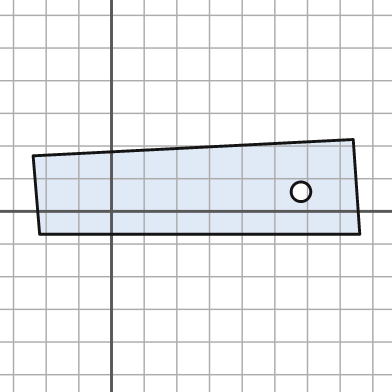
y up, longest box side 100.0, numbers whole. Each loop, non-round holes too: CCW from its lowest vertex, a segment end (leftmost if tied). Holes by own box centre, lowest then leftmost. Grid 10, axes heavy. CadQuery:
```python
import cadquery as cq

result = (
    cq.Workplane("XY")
    .moveTo(-22.0, -7.0)
    .lineTo(76.0, -7.0)
    .lineTo(74.0, 22.0)
    .lineTo(-24.0, 17.0)
    .close()
    .moveTo(58.0, 6.0)
    .circle(3.0)
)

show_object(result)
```